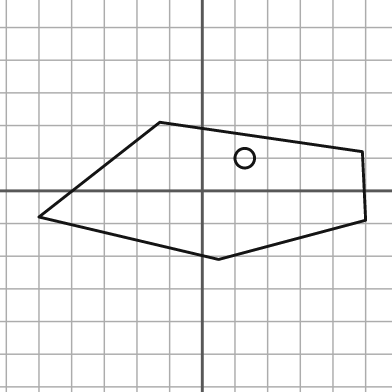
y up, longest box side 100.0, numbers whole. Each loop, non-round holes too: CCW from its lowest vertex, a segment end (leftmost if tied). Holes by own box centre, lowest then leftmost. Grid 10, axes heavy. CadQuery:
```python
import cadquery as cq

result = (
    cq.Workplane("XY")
    .moveTo(5.0, -21.0)
    .lineTo(50.0, -9.0)
    .lineTo(49.0, 12.0)
    .lineTo(-13.0, 21.0)
    .lineTo(-50.0, -8.0)
    .close()
    .moveTo(13.0, 10.0)
    .circle(3.0)
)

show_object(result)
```